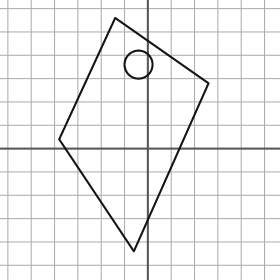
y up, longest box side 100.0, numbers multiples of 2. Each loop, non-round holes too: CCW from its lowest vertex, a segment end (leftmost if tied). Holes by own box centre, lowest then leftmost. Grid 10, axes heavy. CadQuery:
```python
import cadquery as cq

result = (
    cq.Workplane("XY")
    .moveTo(-6.0, -44.0)
    .lineTo(26.0, 28.0)
    .lineTo(-14.0, 56.0)
    .lineTo(-38.0, 4.0)
    .close()
    .moveTo(-4.0, 36.0)
    .circle(6.0)
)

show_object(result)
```